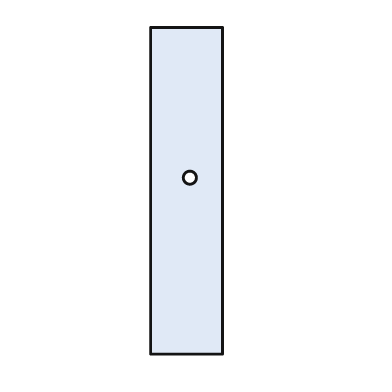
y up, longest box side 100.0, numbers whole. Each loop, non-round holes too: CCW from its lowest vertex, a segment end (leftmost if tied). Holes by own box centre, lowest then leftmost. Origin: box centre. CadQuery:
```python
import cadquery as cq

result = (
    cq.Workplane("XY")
    .moveTo(-11.0, -50.0)
    .lineTo(11.0, -50.0)
    .lineTo(11.0, 50.0)
    .lineTo(-11.0, 50.0)
    .close()
    .moveTo(1.0, 4.0)
    .circle(2.0)
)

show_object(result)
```